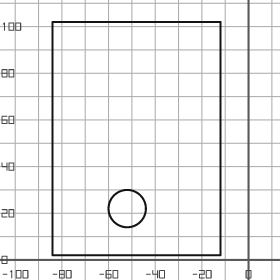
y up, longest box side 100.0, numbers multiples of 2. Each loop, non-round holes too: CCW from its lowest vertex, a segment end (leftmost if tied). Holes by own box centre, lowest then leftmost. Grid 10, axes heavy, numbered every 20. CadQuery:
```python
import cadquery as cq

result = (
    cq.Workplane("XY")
    .moveTo(-84.0, 2.0)
    .lineTo(-12.0, 2.0)
    .lineTo(-12.0, 102.0)
    .lineTo(-84.0, 102.0)
    .close()
    .moveTo(-52.0, 22.0)
    .circle(8.0)
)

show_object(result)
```